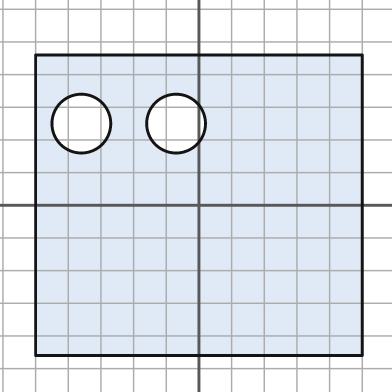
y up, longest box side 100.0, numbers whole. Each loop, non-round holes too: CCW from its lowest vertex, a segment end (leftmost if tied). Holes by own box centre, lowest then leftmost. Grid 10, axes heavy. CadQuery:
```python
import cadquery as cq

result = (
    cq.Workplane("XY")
    .moveTo(-50.0, -46.0)
    .lineTo(50.0, -46.0)
    .lineTo(50.0, 46.0)
    .lineTo(-50.0, 46.0)
    .close()
    .moveTo(-36.0, 25.0)
    .circle(9.0)
    .moveTo(-7.0, 25.0)
    .circle(9.0)
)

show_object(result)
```